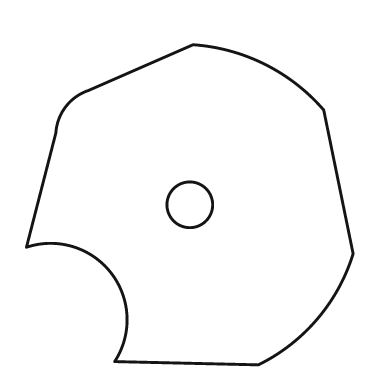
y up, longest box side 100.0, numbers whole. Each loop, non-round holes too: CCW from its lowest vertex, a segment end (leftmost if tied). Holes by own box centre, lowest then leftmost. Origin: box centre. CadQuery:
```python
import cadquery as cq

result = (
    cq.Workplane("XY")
    .moveTo(21.0, -49.0)
    .threePointArc((39.0, -35.0), (50.0, -15.0))
    .lineTo(41.0, 29.0)
    .threePointArc((23.0, 43.0), (1.0, 49.0))
    .lineTo(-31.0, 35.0)
    .threePointArc((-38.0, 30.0), (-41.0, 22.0))
    .lineTo(-50.0, -13.0)
    .threePointArc((-24.0, -21.0), (-23.0, -48.0))
    .close()
    .moveTo(0.0, 0.0)
    .circle(7.0)
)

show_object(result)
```